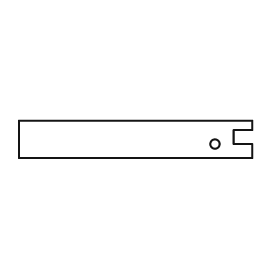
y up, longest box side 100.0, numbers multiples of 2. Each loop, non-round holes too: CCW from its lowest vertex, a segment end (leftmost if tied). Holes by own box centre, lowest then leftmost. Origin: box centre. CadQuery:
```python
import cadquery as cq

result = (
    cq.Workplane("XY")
    .moveTo(-50.0, -8.0)
    .lineTo(50.0, -8.0)
    .lineTo(50.0, -2.0)
    .lineTo(42.0, -2.0)
    .lineTo(42.0, 4.0)
    .lineTo(50.0, 4.0)
    .lineTo(50.0, 8.0)
    .lineTo(-50.0, 8.0)
    .close()
    .moveTo(34.0, -2.0)
    .circle(2.0)
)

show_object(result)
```